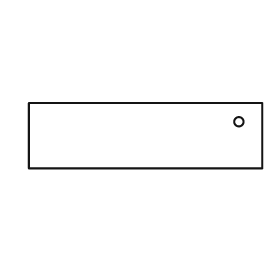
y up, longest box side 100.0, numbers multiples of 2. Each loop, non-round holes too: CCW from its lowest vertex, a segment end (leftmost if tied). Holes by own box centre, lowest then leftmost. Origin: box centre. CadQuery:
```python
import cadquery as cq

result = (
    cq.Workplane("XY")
    .moveTo(-50.0, -14.0)
    .lineTo(50.0, -14.0)
    .lineTo(50.0, 14.0)
    .lineTo(-50.0, 14.0)
    .close()
    .moveTo(40.0, 6.0)
    .circle(2.0)
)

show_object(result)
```